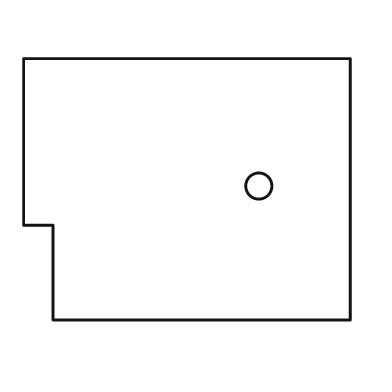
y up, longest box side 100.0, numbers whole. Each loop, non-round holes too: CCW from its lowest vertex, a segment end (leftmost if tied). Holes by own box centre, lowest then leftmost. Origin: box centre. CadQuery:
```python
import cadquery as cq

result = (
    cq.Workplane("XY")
    .moveTo(-41.0, -40.0)
    .lineTo(50.0, -40.0)
    .lineTo(50.0, 40.0)
    .lineTo(-50.0, 40.0)
    .lineTo(-50.0, -11.0)
    .lineTo(-41.0, -11.0)
    .close()
    .moveTo(22.0, 1.0)
    .circle(4.0)
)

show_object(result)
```